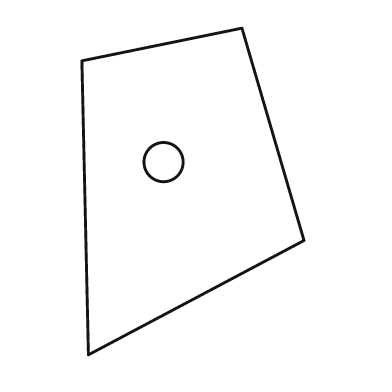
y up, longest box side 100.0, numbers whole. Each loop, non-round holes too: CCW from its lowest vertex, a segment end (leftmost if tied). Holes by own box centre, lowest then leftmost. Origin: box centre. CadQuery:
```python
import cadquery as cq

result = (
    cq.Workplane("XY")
    .moveTo(-32.0, -50.0)
    .lineTo(34.0, -15.0)
    .lineTo(15.0, 50.0)
    .lineTo(-34.0, 40.0)
    .close()
    .moveTo(-9.0, 9.0)
    .circle(6.0)
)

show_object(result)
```